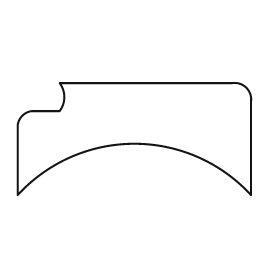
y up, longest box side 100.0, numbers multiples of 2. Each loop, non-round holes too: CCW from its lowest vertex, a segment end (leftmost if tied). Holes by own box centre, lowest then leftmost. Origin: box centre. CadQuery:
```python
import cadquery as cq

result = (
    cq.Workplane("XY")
    .moveTo(-50.0, -24.0)
    .threePointArc((0.0, -2.0), (50.0, -24.0))
    .lineTo(50.0, 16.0)
    .threePointArc((48.0, 22.0), (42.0, 24.0))
    .lineTo(-32.0, 24.0)
    .threePointArc((-30.0, 18.0), (-32.0, 12.0))
    .lineTo(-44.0, 12.0)
    .threePointArc((-48.0, 10.0), (-50.0, 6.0))
    .close()
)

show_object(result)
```